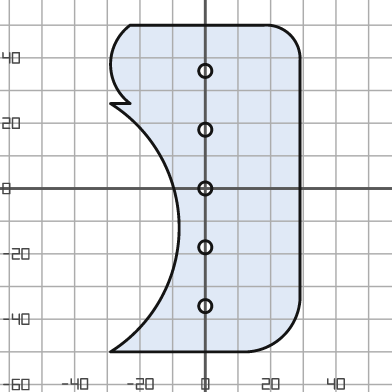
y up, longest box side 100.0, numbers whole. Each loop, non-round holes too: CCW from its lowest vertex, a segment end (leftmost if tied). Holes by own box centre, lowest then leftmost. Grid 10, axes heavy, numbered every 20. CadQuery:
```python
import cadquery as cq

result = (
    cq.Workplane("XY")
    .moveTo(-29.0, -50.0)
    .lineTo(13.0, -50.0)
    .threePointArc((24.0, -45.0), (29.0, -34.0))
    .lineTo(29.0, 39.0)
    .threePointArc((26.0, 47.0), (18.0, 50.0))
    .lineTo(-23.0, 50.0)
    .threePointArc((-29.0, 38.0), (-23.0, 26.0))
    .lineTo(-29.0, 26.0)
    .threePointArc((-8.0, -12.0), (-29.0, -50.0))
    .close()
    .moveTo(0.0, -36.0)
    .circle(2.0)
    .moveTo(0.0, -18.0)
    .circle(2.0)
    .moveTo(0.0, 0.0)
    .circle(2.0)
    .moveTo(0.0, 18.0)
    .circle(2.0)
    .moveTo(0.0, 36.0)
    .circle(2.0)
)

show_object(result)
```